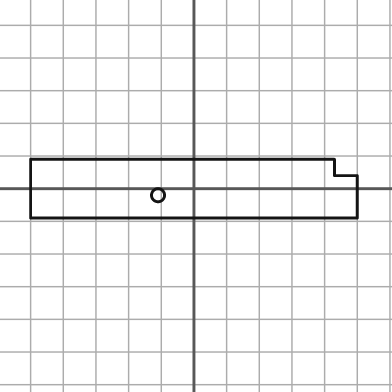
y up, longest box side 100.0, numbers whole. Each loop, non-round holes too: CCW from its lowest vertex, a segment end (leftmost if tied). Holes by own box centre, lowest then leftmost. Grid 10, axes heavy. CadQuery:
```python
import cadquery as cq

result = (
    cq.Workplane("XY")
    .moveTo(-50.0, -9.0)
    .lineTo(50.0, -9.0)
    .lineTo(50.0, 4.0)
    .lineTo(43.0, 4.0)
    .lineTo(43.0, 9.0)
    .lineTo(-50.0, 9.0)
    .close()
    .moveTo(-11.0, -2.0)
    .circle(2.0)
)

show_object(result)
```